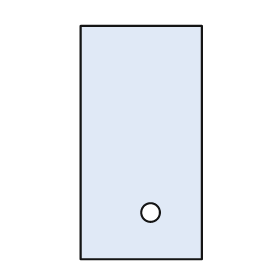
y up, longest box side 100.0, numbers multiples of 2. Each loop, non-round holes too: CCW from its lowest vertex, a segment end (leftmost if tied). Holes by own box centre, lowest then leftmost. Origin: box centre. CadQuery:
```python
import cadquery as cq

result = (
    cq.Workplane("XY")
    .moveTo(-26.0, -50.0)
    .lineTo(26.0, -50.0)
    .lineTo(26.0, 50.0)
    .lineTo(-26.0, 50.0)
    .close()
    .moveTo(4.0, -30.0)
    .circle(4.0)
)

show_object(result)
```